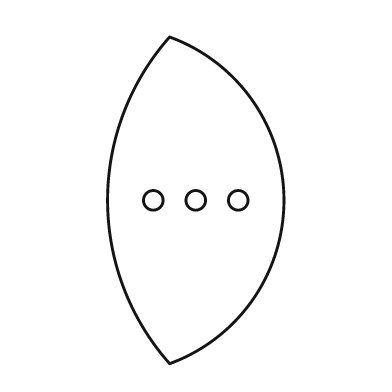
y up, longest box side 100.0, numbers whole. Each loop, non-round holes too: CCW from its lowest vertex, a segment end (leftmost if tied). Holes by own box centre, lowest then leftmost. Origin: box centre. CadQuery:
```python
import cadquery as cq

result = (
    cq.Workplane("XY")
    .moveTo(-8.0, -50.0)
    .threePointArc((27.0, 0.0), (-8.0, 50.0))
    .threePointArc((-27.0, 0.0), (-8.0, -50.0))
    .close()
    .moveTo(-13.0, 0.0)
    .circle(3.0)
    .moveTo(0.0, 0.0)
    .circle(3.0)
    .moveTo(13.0, 0.0)
    .circle(3.0)
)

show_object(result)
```